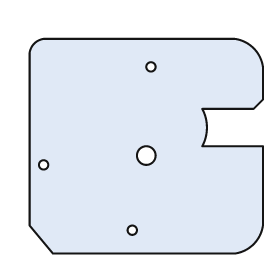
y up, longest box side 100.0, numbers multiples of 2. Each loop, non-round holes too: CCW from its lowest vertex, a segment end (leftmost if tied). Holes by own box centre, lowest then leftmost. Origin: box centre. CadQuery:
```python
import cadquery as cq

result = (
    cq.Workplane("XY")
    .moveTo(-40.0, -46.0)
    .lineTo(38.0, -46.0)
    .threePointArc((46.0, -42.0), (50.0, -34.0))
    .lineTo(50.0, 0.0)
    .lineTo(24.0, 0.0)
    .threePointArc((26.0, 8.0), (24.0, 16.0))
    .lineTo(46.0, 16.0)
    .lineTo(50.0, 20.0)
    .lineTo(50.0, 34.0)
    .threePointArc((46.0, 42.0), (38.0, 46.0))
    .lineTo(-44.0, 46.0)
    .threePointArc((-48.0, 44.0), (-50.0, 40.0))
    .lineTo(-50.0, -34.0)
    .close()
    .moveTo(-6.0, -36.0)
    .circle(2.0)
    .moveTo(-44.0, -8.0)
    .circle(2.0)
    .moveTo(0.0, -4.0)
    .circle(4.0)
    .moveTo(2.0, 34.0)
    .circle(2.0)
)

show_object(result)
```